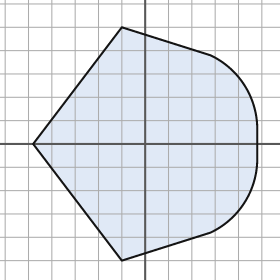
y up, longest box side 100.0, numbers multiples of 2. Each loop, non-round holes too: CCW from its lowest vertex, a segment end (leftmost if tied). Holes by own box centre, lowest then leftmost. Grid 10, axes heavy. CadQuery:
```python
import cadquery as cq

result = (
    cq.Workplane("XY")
    .moveTo(-10.0, -50.0)
    .lineTo(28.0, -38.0)
    .threePointArc((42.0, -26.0), (48.0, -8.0))
    .lineTo(48.0, 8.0)
    .threePointArc((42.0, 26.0), (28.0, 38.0))
    .lineTo(-10.0, 50.0)
    .lineTo(-48.0, 0.0)
    .close()
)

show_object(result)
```